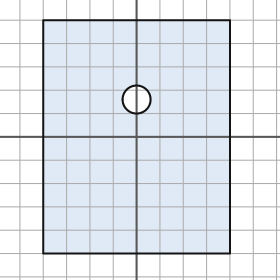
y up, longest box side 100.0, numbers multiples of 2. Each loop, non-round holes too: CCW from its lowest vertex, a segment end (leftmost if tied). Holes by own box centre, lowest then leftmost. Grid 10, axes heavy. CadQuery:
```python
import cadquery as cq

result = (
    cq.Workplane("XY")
    .moveTo(-40.0, -50.0)
    .lineTo(40.0, -50.0)
    .lineTo(40.0, 50.0)
    .lineTo(-40.0, 50.0)
    .close()
    .moveTo(0.0, 16.0)
    .circle(6.0)
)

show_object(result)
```